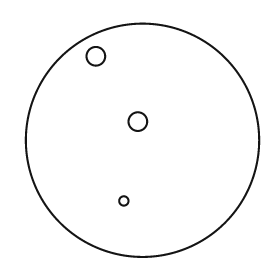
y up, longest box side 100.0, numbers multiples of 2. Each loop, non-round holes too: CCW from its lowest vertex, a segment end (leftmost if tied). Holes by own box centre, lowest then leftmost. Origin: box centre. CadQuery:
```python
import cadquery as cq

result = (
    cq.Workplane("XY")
    .moveTo(0.0, 0.0)
    .circle(50.0)
    .moveTo(-8.0, -26.0)
    .circle(2.0)
    .moveTo(-2.0, 8.0)
    .circle(4.0)
    .moveTo(-20.0, 36.0)
    .circle(4.0)
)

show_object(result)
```